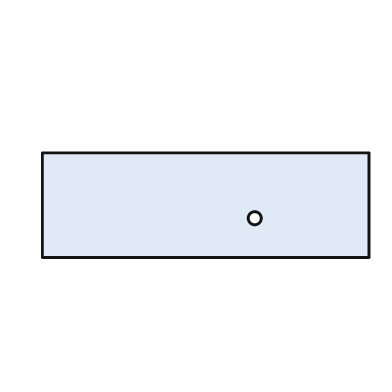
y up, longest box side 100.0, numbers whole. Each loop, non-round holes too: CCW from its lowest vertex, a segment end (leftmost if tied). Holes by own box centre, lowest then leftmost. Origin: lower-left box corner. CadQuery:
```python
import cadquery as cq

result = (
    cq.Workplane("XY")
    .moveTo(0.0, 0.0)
    .lineTo(100.0, 0.0)
    .lineTo(100.0, 32.0)
    .lineTo(0.0, 32.0)
    .close()
    .moveTo(65.0, 12.0)
    .circle(2.0)
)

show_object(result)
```